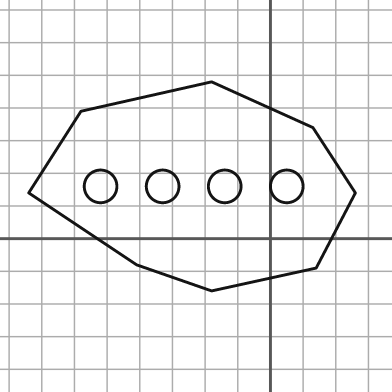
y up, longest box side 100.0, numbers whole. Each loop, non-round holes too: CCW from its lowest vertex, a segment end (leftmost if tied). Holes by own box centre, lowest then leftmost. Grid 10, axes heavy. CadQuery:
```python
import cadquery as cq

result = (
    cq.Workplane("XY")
    .moveTo(-18.0, -16.0)
    .lineTo(14.0, -9.0)
    .lineTo(26.0, 14.0)
    .lineTo(13.0, 34.0)
    .lineTo(-18.0, 48.0)
    .lineTo(-58.0, 39.0)
    .lineTo(-74.0, 14.0)
    .lineTo(-41.0, -8.0)
    .close()
    .moveTo(-52.0, 16.0)
    .circle(5.0)
    .moveTo(-33.0, 16.0)
    .circle(5.0)
    .moveTo(-14.0, 16.0)
    .circle(5.0)
    .moveTo(5.0, 16.0)
    .circle(5.0)
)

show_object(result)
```